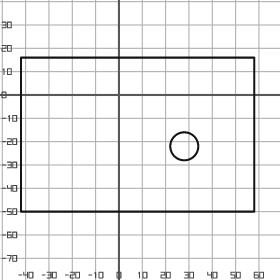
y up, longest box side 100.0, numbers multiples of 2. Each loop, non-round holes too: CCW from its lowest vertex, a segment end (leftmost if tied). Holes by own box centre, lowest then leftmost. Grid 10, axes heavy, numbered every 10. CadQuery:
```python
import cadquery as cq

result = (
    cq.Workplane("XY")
    .moveTo(-42.0, -50.0)
    .lineTo(58.0, -50.0)
    .lineTo(58.0, 16.0)
    .lineTo(-42.0, 16.0)
    .close()
    .moveTo(28.0, -22.0)
    .circle(6.0)
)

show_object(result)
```